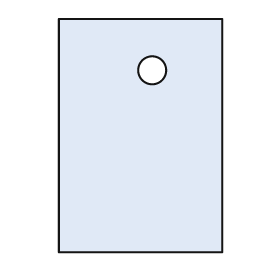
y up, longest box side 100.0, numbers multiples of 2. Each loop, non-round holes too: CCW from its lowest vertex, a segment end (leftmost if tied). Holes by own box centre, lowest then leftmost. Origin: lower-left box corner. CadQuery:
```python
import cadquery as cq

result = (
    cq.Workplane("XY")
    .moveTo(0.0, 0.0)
    .lineTo(70.0, 0.0)
    .lineTo(70.0, 100.0)
    .lineTo(0.0, 100.0)
    .close()
    .moveTo(40.0, 78.0)
    .circle(6.0)
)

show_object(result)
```